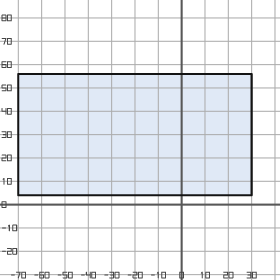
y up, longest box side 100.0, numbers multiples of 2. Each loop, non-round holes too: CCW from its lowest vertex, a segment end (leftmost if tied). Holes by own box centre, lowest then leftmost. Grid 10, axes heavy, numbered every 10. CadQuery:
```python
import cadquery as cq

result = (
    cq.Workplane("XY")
    .moveTo(-70.0, 4.0)
    .lineTo(30.0, 4.0)
    .lineTo(30.0, 56.0)
    .lineTo(-70.0, 56.0)
    .close()
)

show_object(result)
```